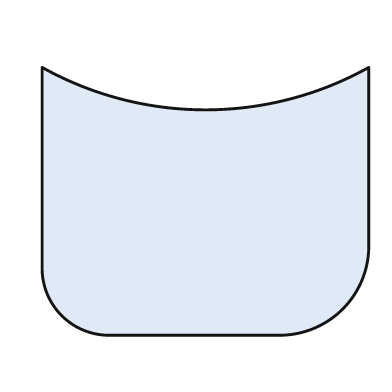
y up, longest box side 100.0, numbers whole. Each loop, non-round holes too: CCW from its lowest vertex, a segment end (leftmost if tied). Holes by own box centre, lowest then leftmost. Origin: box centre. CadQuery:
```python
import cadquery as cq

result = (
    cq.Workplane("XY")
    .moveTo(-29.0, -41.0)
    .lineTo(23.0, -41.0)
    .threePointArc((42.0, -33.0), (50.0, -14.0))
    .lineTo(50.0, 41.0)
    .threePointArc((0.0, 28.0), (-50.0, 41.0))
    .lineTo(-50.0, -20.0)
    .threePointArc((-44.0, -35.0), (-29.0, -41.0))
    .close()
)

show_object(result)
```